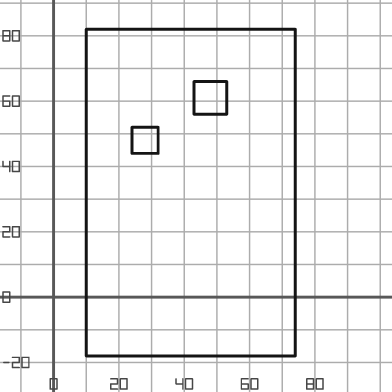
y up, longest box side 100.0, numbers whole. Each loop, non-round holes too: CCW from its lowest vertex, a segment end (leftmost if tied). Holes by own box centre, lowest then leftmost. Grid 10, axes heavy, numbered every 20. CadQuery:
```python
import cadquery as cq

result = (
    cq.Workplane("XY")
    .moveTo(10.0, -18.0)
    .lineTo(74.0, -18.0)
    .lineTo(74.0, 82.0)
    .lineTo(10.0, 82.0)
    .close()
    .moveTo(24.0, 44.0)
    .lineTo(32.0, 44.0)
    .lineTo(32.0, 52.0)
    .lineTo(24.0, 52.0)
    .close()
    .moveTo(43.0, 56.0)
    .lineTo(53.0, 56.0)
    .lineTo(53.0, 66.0)
    .lineTo(43.0, 66.0)
    .close()
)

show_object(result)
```